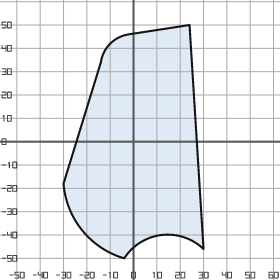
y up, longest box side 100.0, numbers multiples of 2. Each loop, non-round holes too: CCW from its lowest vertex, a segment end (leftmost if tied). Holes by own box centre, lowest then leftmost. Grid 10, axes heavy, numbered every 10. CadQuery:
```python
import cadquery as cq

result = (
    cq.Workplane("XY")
    .moveTo(-4.0, -50.0)
    .threePointArc((12.0, -40.0), (30.0, -46.0))
    .lineTo(24.0, 50.0)
    .lineTo(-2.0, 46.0)
    .threePointArc((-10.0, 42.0), (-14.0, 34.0))
    .lineTo(-30.0, -18.0)
    .threePointArc((-22.0, -38.0), (-4.0, -50.0))
    .close()
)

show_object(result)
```